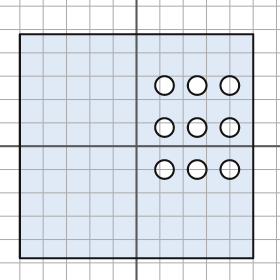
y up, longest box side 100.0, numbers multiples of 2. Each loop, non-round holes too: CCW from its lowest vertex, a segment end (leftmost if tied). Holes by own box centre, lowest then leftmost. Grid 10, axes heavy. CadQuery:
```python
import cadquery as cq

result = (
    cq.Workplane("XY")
    .moveTo(-50.0, -48.0)
    .lineTo(50.0, -48.0)
    .lineTo(50.0, 48.0)
    .lineTo(-50.0, 48.0)
    .close()
    .moveTo(12.0, -10.0)
    .circle(4.0)
    .moveTo(26.0, -10.0)
    .circle(4.0)
    .moveTo(40.0, -10.0)
    .circle(4.0)
    .moveTo(12.0, 8.0)
    .circle(4.0)
    .moveTo(26.0, 8.0)
    .circle(4.0)
    .moveTo(40.0, 8.0)
    .circle(4.0)
    .moveTo(12.0, 26.0)
    .circle(4.0)
    .moveTo(26.0, 26.0)
    .circle(4.0)
    .moveTo(40.0, 26.0)
    .circle(4.0)
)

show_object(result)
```